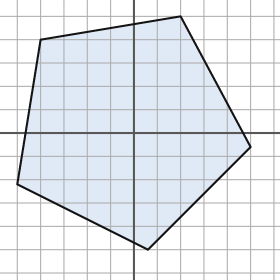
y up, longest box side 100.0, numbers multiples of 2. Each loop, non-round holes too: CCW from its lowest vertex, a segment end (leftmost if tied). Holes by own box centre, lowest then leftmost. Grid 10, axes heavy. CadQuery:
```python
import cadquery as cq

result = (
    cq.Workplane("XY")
    .moveTo(6.0, -50.0)
    .lineTo(50.0, -6.0)
    .lineTo(20.0, 50.0)
    .lineTo(-40.0, 40.0)
    .lineTo(-50.0, -22.0)
    .close()
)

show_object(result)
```